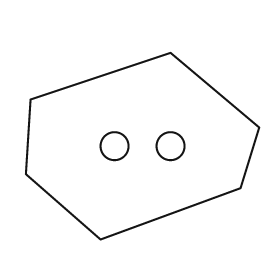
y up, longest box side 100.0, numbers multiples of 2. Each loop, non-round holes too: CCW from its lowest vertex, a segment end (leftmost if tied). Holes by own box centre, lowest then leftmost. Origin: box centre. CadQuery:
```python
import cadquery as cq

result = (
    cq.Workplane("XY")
    .moveTo(-18.0, -40.0)
    .lineTo(42.0, -18.0)
    .lineTo(50.0, 8.0)
    .lineTo(12.0, 40.0)
    .lineTo(-48.0, 20.0)
    .lineTo(-50.0, -12.0)
    .close()
    .moveTo(-12.0, 0.0)
    .circle(6.0)
    .moveTo(12.0, 0.0)
    .circle(6.0)
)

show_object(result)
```